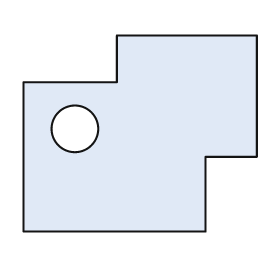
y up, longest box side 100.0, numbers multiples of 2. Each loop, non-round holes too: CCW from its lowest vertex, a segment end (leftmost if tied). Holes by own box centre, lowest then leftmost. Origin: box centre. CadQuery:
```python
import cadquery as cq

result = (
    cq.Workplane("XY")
    .moveTo(-50.0, -42.0)
    .lineTo(28.0, -42.0)
    .lineTo(28.0, -10.0)
    .lineTo(50.0, -10.0)
    .lineTo(50.0, 42.0)
    .lineTo(-10.0, 42.0)
    .lineTo(-10.0, 22.0)
    .lineTo(-50.0, 22.0)
    .close()
    .moveTo(-28.0, 2.0)
    .circle(10.0)
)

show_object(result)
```